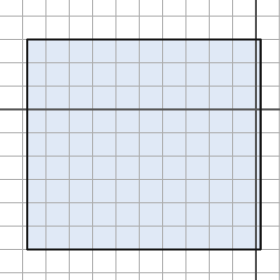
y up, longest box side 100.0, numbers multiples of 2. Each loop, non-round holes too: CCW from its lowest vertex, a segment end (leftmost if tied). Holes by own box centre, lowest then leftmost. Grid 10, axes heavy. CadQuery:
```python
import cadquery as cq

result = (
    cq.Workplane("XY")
    .moveTo(-98.0, -60.0)
    .lineTo(2.0, -60.0)
    .lineTo(2.0, 30.0)
    .lineTo(-98.0, 30.0)
    .close()
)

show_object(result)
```